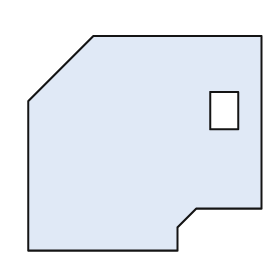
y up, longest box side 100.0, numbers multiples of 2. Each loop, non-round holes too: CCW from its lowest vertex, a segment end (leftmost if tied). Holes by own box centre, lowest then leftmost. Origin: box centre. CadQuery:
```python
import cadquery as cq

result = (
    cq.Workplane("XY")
    .moveTo(-50.0, -46.0)
    .lineTo(14.0, -46.0)
    .lineTo(14.0, -36.0)
    .lineTo(22.0, -28.0)
    .lineTo(50.0, -28.0)
    .lineTo(50.0, 46.0)
    .lineTo(-22.0, 46.0)
    .lineTo(-50.0, 18.0)
    .close()
    .moveTo(28.0, 6.0)
    .lineTo(40.0, 6.0)
    .lineTo(40.0, 22.0)
    .lineTo(28.0, 22.0)
    .close()
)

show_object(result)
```